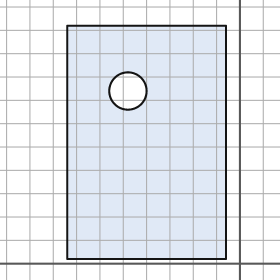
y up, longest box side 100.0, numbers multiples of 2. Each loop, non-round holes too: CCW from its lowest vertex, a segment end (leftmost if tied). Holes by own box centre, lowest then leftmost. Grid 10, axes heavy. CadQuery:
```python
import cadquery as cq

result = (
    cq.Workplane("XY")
    .moveTo(-74.0, 2.0)
    .lineTo(-6.0, 2.0)
    .lineTo(-6.0, 102.0)
    .lineTo(-74.0, 102.0)
    .close()
    .moveTo(-48.0, 74.0)
    .circle(8.0)
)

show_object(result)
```